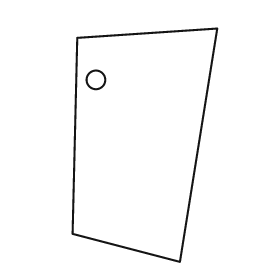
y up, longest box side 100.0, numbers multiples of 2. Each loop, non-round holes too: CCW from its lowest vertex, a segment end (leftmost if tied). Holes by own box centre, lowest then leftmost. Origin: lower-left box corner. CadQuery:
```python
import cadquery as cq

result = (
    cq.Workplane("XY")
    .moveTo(46.0, 0.0)
    .lineTo(62.0, 100.0)
    .lineTo(2.0, 96.0)
    .lineTo(0.0, 12.0)
    .close()
    .moveTo(10.0, 78.0)
    .circle(4.0)
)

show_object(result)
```